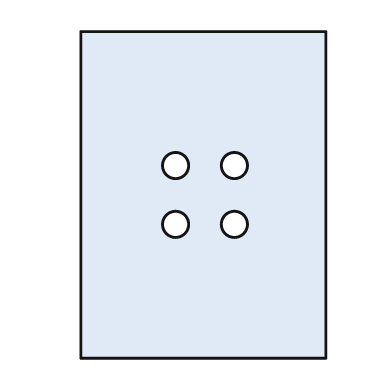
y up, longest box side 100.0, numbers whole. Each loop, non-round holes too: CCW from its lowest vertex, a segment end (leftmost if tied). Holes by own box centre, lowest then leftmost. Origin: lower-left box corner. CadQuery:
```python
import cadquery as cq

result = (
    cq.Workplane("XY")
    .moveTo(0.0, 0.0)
    .lineTo(75.0, 0.0)
    .lineTo(75.0, 100.0)
    .lineTo(0.0, 100.0)
    .close()
    .moveTo(29.0, 41.0)
    .circle(4.0)
    .moveTo(47.0, 41.0)
    .circle(4.0)
    .moveTo(29.0, 59.0)
    .circle(4.0)
    .moveTo(47.0, 59.0)
    .circle(4.0)
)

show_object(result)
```